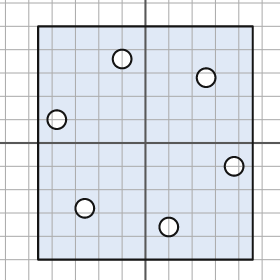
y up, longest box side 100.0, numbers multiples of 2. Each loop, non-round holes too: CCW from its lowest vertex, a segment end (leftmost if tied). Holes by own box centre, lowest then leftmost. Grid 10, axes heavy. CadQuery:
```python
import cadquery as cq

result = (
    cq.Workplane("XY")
    .moveTo(-46.0, -50.0)
    .lineTo(46.0, -50.0)
    .lineTo(46.0, 50.0)
    .lineTo(-46.0, 50.0)
    .close()
    .moveTo(10.0, -36.0)
    .circle(4.0)
    .moveTo(-26.0, -28.0)
    .circle(4.0)
    .moveTo(38.0, -10.0)
    .circle(4.0)
    .moveTo(-38.0, 10.0)
    .circle(4.0)
    .moveTo(26.0, 28.0)
    .circle(4.0)
    .moveTo(-10.0, 36.0)
    .circle(4.0)
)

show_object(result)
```